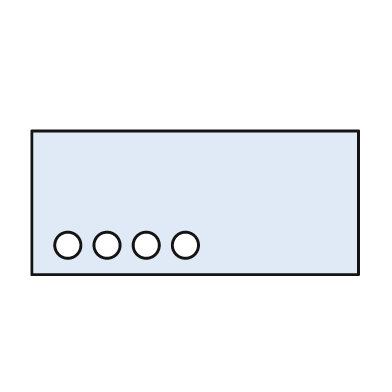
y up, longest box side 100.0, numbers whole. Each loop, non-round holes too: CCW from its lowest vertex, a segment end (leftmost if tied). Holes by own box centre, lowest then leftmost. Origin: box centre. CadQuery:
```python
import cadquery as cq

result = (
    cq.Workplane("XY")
    .moveTo(-50.0, -22.0)
    .lineTo(50.0, -22.0)
    .lineTo(50.0, 22.0)
    .lineTo(-50.0, 22.0)
    .close()
    .moveTo(-39.0, -13.0)
    .circle(4.0)
    .moveTo(-27.0, -13.0)
    .circle(4.0)
    .moveTo(-15.0, -13.0)
    .circle(4.0)
    .moveTo(-3.0, -13.0)
    .circle(4.0)
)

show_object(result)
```